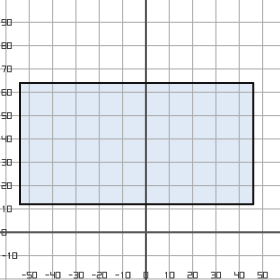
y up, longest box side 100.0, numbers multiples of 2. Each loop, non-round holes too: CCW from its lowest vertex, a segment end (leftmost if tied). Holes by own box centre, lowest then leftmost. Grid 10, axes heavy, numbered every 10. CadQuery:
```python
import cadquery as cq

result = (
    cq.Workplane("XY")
    .moveTo(-54.0, 12.0)
    .lineTo(46.0, 12.0)
    .lineTo(46.0, 64.0)
    .lineTo(-54.0, 64.0)
    .close()
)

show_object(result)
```